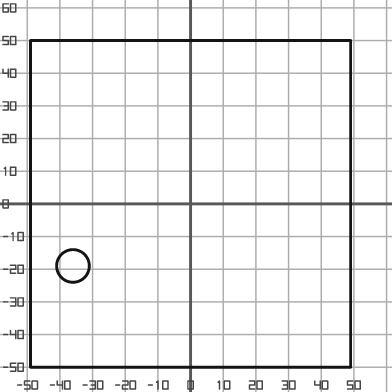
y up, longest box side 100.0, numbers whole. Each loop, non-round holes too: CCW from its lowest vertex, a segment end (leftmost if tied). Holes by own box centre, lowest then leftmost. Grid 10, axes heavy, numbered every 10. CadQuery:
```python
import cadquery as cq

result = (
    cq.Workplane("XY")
    .moveTo(-49.0, -50.0)
    .lineTo(49.0, -50.0)
    .lineTo(49.0, 50.0)
    .lineTo(-49.0, 50.0)
    .close()
    .moveTo(-36.0, -19.0)
    .circle(5.0)
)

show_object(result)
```